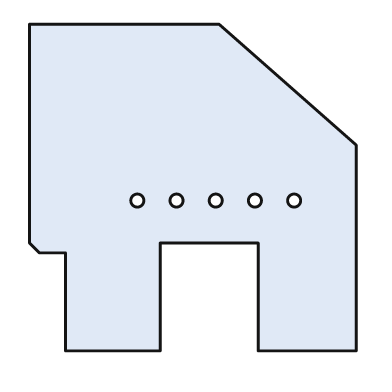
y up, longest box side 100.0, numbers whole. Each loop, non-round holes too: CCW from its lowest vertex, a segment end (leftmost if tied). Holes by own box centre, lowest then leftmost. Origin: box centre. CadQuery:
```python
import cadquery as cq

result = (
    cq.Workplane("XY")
    .moveTo(-39.0, -50.0)
    .lineTo(-10.0, -50.0)
    .lineTo(-10.0, -17.0)
    .lineTo(20.0, -17.0)
    .lineTo(20.0, -50.0)
    .lineTo(50.0, -50.0)
    .lineTo(50.0, 13.0)
    .lineTo(8.0, 50.0)
    .lineTo(-50.0, 50.0)
    .lineTo(-50.0, -17.0)
    .lineTo(-47.0, -20.0)
    .lineTo(-39.0, -20.0)
    .close()
    .moveTo(-17.0, -4.0)
    .circle(2.0)
    .moveTo(-5.0, -4.0)
    .circle(2.0)
    .moveTo(7.0, -4.0)
    .circle(2.0)
    .moveTo(19.0, -4.0)
    .circle(2.0)
    .moveTo(31.0, -4.0)
    .circle(2.0)
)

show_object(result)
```